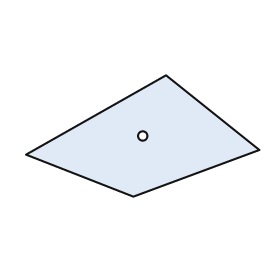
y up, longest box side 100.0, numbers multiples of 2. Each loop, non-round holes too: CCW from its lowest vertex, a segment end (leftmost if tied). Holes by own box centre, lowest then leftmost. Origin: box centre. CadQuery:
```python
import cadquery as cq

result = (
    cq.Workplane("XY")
    .moveTo(-4.0, -26.0)
    .lineTo(50.0, -6.0)
    .lineTo(10.0, 26.0)
    .lineTo(-50.0, -8.0)
    .close()
    .moveTo(0.0, 0.0)
    .circle(2.0)
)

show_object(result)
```